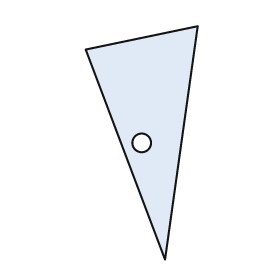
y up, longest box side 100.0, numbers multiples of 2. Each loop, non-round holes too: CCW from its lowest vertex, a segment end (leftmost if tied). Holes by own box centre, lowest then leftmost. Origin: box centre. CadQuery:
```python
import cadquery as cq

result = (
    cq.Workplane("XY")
    .moveTo(10.0, -50.0)
    .lineTo(24.0, 50.0)
    .lineTo(-24.0, 40.0)
    .close()
    .moveTo(0.0, 0.0)
    .circle(4.0)
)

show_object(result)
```